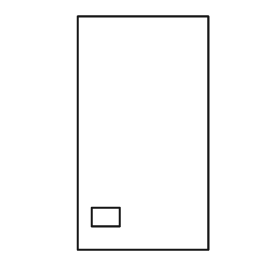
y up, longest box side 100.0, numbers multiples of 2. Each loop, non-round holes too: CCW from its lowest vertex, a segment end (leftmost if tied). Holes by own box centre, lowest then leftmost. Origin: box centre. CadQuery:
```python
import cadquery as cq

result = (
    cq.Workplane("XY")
    .moveTo(-28.0, -50.0)
    .lineTo(28.0, -50.0)
    .lineTo(28.0, 50.0)
    .lineTo(-28.0, 50.0)
    .close()
    .moveTo(-22.0, -40.0)
    .lineTo(-10.0, -40.0)
    .lineTo(-10.0, -32.0)
    .lineTo(-22.0, -32.0)
    .close()
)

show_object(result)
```